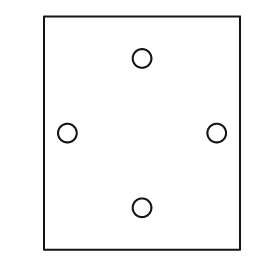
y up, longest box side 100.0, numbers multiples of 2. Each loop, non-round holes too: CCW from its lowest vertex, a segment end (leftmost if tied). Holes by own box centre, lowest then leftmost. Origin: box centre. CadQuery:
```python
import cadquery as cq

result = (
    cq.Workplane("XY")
    .moveTo(-42.0, -50.0)
    .lineTo(42.0, -50.0)
    .lineTo(42.0, 50.0)
    .lineTo(-42.0, 50.0)
    .close()
    .moveTo(0.0, -32.0)
    .circle(4.0)
    .moveTo(-32.0, 0.0)
    .circle(4.0)
    .moveTo(32.0, 0.0)
    .circle(4.0)
    .moveTo(0.0, 32.0)
    .circle(4.0)
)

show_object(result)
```